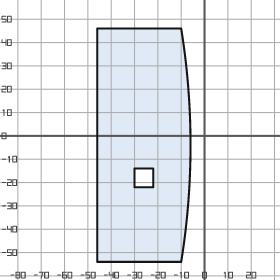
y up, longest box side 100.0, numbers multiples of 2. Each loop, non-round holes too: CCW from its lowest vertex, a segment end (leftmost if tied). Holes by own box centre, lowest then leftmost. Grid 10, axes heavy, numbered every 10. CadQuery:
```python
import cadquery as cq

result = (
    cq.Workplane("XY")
    .moveTo(-46.0, -54.0)
    .lineTo(-10.0, -54.0)
    .threePointArc((-6.0, -4.0), (-10.0, 46.0))
    .lineTo(-46.0, 46.0)
    .close()
    .moveTo(-30.0, -22.0)
    .lineTo(-22.0, -22.0)
    .lineTo(-22.0, -14.0)
    .lineTo(-30.0, -14.0)
    .close()
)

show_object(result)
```